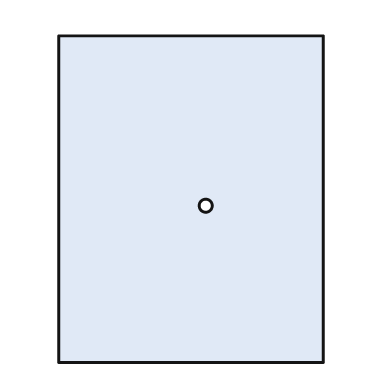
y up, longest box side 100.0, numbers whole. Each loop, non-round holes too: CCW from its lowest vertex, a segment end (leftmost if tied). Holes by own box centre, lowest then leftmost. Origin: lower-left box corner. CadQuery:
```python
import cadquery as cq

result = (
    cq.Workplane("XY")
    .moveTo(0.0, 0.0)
    .lineTo(81.0, 0.0)
    .lineTo(81.0, 100.0)
    .lineTo(0.0, 100.0)
    .close()
    .moveTo(45.0, 48.0)
    .circle(2.0)
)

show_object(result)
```